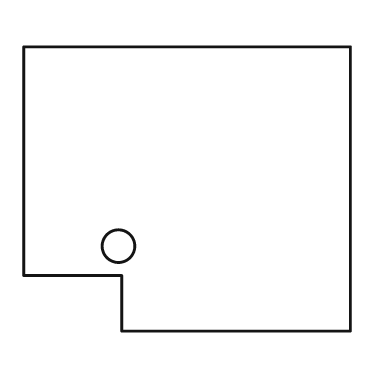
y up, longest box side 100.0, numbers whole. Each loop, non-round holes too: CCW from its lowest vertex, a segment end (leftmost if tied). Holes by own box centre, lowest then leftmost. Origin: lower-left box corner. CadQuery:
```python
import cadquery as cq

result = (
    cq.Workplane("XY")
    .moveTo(30.0, 0.0)
    .lineTo(100.0, 0.0)
    .lineTo(100.0, 87.0)
    .lineTo(0.0, 87.0)
    .lineTo(0.0, 17.0)
    .lineTo(30.0, 17.0)
    .close()
    .moveTo(29.0, 26.0)
    .circle(5.0)
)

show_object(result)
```